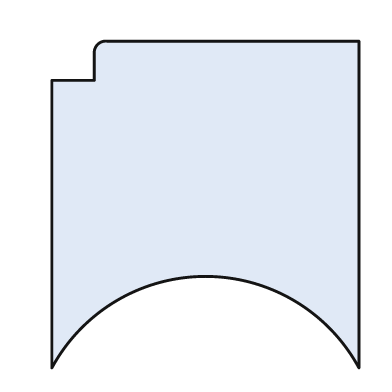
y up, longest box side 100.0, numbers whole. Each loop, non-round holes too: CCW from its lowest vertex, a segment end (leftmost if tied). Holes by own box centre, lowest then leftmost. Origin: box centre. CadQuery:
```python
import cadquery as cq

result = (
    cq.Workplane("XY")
    .moveTo(-47.0, -50.0)
    .threePointArc((0.0, -22.0), (47.0, -50.0))
    .lineTo(47.0, 50.0)
    .lineTo(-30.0, 50.0)
    .threePointArc((-33.0, 49.0), (-34.0, 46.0))
    .lineTo(-34.0, 38.0)
    .lineTo(-47.0, 38.0)
    .close()
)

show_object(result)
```